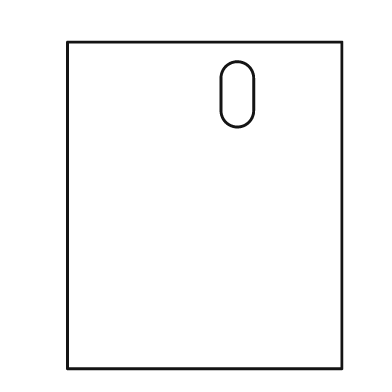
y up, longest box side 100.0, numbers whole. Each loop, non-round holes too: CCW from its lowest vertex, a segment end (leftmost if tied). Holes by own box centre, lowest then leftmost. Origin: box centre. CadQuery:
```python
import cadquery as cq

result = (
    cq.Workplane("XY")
    .moveTo(-42.0, -50.0)
    .lineTo(42.0, -50.0)
    .lineTo(42.0, 50.0)
    .lineTo(-42.0, 50.0)
    .close()
    .moveTo(5.0, 29.0)
    .threePointArc((10.0, 24.0), (15.0, 29.0))
    .lineTo(15.0, 39.0)
    .threePointArc((10.0, 44.0), (5.0, 39.0))
    .close()
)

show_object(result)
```